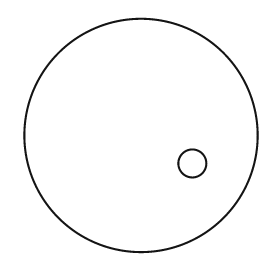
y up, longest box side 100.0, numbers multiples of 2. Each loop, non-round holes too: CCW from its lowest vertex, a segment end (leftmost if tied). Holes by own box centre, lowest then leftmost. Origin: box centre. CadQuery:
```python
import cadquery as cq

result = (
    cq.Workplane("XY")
    .moveTo(0.0, 0.0)
    .circle(50.0)
    .moveTo(22.0, -12.0)
    .circle(6.0)
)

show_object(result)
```